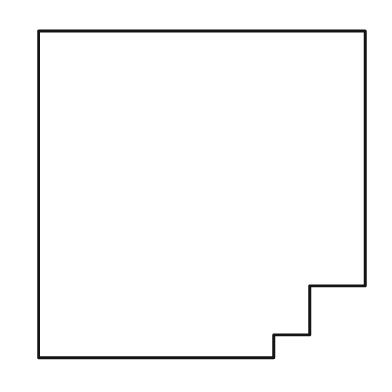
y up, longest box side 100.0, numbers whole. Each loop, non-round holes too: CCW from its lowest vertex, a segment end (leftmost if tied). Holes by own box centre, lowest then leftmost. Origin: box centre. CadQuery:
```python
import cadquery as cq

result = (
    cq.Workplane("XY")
    .moveTo(-50.0, -50.0)
    .lineTo(22.0, -50.0)
    .lineTo(22.0, -43.0)
    .lineTo(33.0, -43.0)
    .lineTo(33.0, -28.0)
    .lineTo(50.0, -28.0)
    .lineTo(50.0, 50.0)
    .lineTo(-50.0, 50.0)
    .close()
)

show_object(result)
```